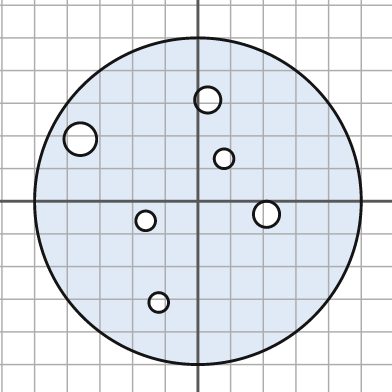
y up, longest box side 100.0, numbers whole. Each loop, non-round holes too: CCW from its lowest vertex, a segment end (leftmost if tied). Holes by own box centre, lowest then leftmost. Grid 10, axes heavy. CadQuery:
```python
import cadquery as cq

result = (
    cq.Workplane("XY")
    .moveTo(0.0, 0.0)
    .circle(50.0)
    .moveTo(-12.0, -31.0)
    .circle(3.0)
    .moveTo(-16.0, -6.0)
    .circle(3.0)
    .moveTo(21.0, -4.0)
    .circle(4.0)
    .moveTo(8.0, 13.0)
    .circle(3.0)
    .moveTo(-36.0, 19.0)
    .circle(5.0)
    .moveTo(3.0, 31.0)
    .circle(4.0)
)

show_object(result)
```